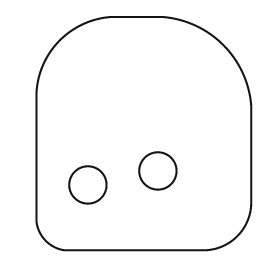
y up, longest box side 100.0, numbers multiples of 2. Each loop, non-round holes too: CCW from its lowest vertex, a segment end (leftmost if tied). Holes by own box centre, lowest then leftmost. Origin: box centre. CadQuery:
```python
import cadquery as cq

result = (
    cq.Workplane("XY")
    .moveTo(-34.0, -50.0)
    .lineTo(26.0, -50.0)
    .threePointArc((40.0, -44.0), (46.0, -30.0))
    .lineTo(46.0, 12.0)
    .threePointArc((34.0, 38.0), (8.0, 50.0))
    .lineTo(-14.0, 50.0)
    .threePointArc((-36.0, 40.0), (-46.0, 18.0))
    .lineTo(-46.0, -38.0)
    .threePointArc((-42.0, -46.0), (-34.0, -50.0))
    .close()
    .moveTo(-24.0, -22.0)
    .circle(8.0)
    .moveTo(6.0, -16.0)
    .circle(8.0)
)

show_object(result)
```